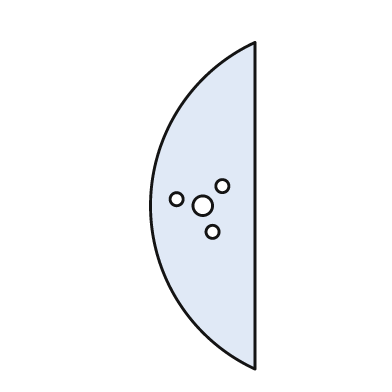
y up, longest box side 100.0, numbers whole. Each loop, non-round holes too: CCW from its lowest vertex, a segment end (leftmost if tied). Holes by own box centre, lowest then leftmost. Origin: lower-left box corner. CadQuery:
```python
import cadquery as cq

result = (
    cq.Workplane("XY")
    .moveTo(32.0, 0.0)
    .lineTo(32.0, 100.0)
    .threePointArc((0.0, 50.0), (32.0, 0.0))
    .close()
    .moveTo(19.0, 42.0)
    .circle(2.0)
    .moveTo(16.0, 50.0)
    .circle(3.0)
    .moveTo(8.0, 52.0)
    .circle(2.0)
    .moveTo(22.0, 56.0)
    .circle(2.0)
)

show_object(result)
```